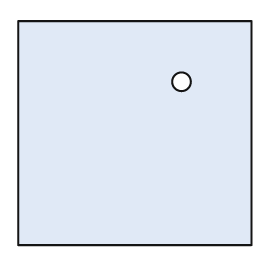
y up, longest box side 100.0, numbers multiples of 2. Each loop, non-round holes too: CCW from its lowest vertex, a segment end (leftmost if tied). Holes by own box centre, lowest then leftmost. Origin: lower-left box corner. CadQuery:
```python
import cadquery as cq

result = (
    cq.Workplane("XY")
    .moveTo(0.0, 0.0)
    .lineTo(100.0, 0.0)
    .lineTo(100.0, 96.0)
    .lineTo(0.0, 96.0)
    .close()
    .moveTo(70.0, 70.0)
    .circle(4.0)
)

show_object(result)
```